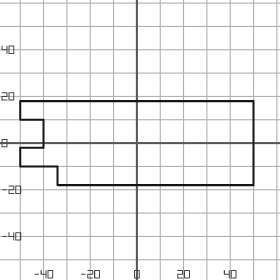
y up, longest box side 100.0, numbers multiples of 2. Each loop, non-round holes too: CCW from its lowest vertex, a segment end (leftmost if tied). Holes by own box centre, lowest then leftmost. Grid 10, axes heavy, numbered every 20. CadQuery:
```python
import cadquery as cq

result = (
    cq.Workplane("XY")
    .moveTo(-34.0, -18.0)
    .lineTo(50.0, -18.0)
    .lineTo(50.0, 18.0)
    .lineTo(-50.0, 18.0)
    .lineTo(-50.0, 10.0)
    .lineTo(-40.0, 10.0)
    .lineTo(-40.0, -2.0)
    .lineTo(-50.0, -2.0)
    .lineTo(-50.0, -10.0)
    .lineTo(-34.0, -10.0)
    .close()
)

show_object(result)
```